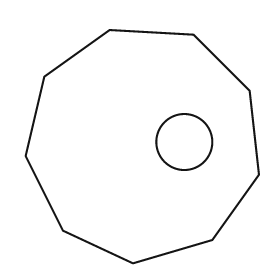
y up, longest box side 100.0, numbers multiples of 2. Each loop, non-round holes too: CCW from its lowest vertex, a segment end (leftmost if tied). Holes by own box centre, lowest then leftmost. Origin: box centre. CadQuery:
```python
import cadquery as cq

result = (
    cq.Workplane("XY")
    .moveTo(-4.0, -50.0)
    .lineTo(30.0, -40.0)
    .lineTo(50.0, -12.0)
    .lineTo(46.0, 24.0)
    .lineTo(22.0, 48.0)
    .lineTo(-14.0, 50.0)
    .lineTo(-42.0, 30.0)
    .lineTo(-50.0, -4.0)
    .lineTo(-34.0, -36.0)
    .close()
    .moveTo(18.0, 2.0)
    .circle(12.0)
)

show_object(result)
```